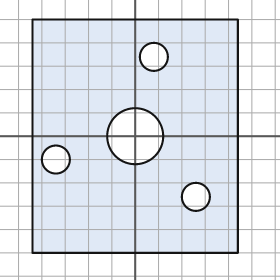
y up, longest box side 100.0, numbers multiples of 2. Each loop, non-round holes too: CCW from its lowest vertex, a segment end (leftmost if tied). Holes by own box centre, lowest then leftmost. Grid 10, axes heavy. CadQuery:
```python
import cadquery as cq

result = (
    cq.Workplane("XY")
    .moveTo(-44.0, -50.0)
    .lineTo(44.0, -50.0)
    .lineTo(44.0, 50.0)
    .lineTo(-44.0, 50.0)
    .close()
    .moveTo(26.0, -26.0)
    .circle(6.0)
    .moveTo(-34.0, -10.0)
    .circle(6.0)
    .moveTo(0.0, 0.0)
    .circle(12.0)
    .moveTo(8.0, 34.0)
    .circle(6.0)
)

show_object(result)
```